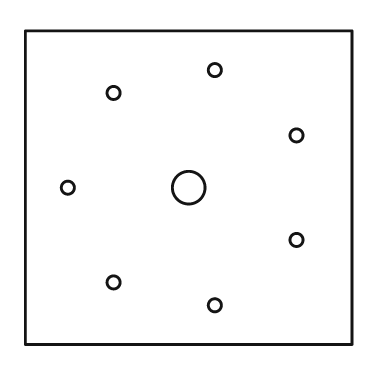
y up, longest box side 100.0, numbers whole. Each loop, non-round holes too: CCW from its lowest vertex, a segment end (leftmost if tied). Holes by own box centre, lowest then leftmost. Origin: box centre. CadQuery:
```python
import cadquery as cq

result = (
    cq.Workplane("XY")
    .moveTo(-50.0, -48.0)
    .lineTo(50.0, -48.0)
    .lineTo(50.0, 48.0)
    .lineTo(-50.0, 48.0)
    .close()
    .moveTo(8.0, -36.0)
    .circle(2.0)
    .moveTo(-23.0, -29.0)
    .circle(2.0)
    .moveTo(33.0, -16.0)
    .circle(2.0)
    .moveTo(-37.0, 0.0)
    .circle(2.0)
    .moveTo(0.0, 0.0)
    .circle(5.0)
    .moveTo(33.0, 16.0)
    .circle(2.0)
    .moveTo(-23.0, 29.0)
    .circle(2.0)
    .moveTo(8.0, 36.0)
    .circle(2.0)
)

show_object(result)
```